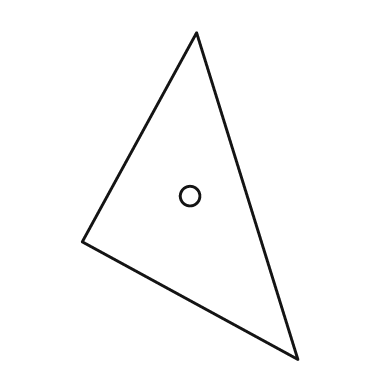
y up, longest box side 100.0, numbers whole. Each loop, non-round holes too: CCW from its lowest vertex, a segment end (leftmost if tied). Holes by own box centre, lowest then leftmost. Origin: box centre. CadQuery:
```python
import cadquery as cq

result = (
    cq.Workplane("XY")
    .moveTo(33.0, -50.0)
    .lineTo(2.0, 50.0)
    .lineTo(-33.0, -14.0)
    .close()
    .moveTo(0.0, 0.0)
    .circle(3.0)
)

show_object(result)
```